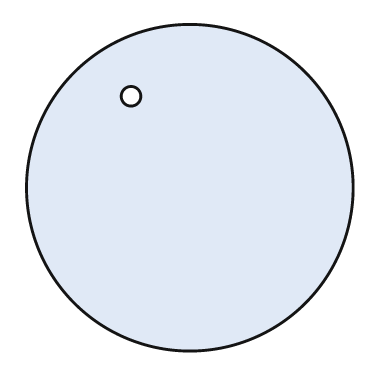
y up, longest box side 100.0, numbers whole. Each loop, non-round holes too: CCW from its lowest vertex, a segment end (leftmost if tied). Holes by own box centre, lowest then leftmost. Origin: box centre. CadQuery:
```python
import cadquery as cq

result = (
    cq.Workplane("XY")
    .moveTo(0.0, 0.0)
    .circle(50.0)
    .moveTo(-18.0, 28.0)
    .circle(3.0)
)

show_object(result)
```